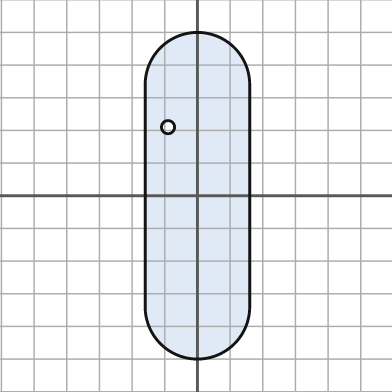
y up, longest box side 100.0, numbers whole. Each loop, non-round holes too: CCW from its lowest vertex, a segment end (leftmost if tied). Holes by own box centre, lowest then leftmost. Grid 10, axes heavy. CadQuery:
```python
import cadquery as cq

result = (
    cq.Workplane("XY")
    .moveTo(-16.0, -34.0)
    .threePointArc((0.0, -50.0), (16.0, -34.0))
    .lineTo(16.0, 34.0)
    .threePointArc((0.0, 50.0), (-16.0, 34.0))
    .close()
    .moveTo(-9.0, 21.0)
    .circle(2.0)
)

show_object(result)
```